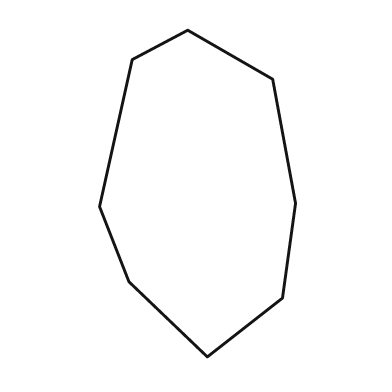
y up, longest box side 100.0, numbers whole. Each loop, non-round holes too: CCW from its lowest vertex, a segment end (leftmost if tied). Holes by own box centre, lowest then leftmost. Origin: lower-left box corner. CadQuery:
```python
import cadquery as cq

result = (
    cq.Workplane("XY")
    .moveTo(33.0, 0.0)
    .lineTo(56.0, 18.0)
    .lineTo(60.0, 47.0)
    .lineTo(53.0, 85.0)
    .lineTo(27.0, 100.0)
    .lineTo(10.0, 91.0)
    .lineTo(0.0, 46.0)
    .lineTo(9.0, 23.0)
    .close()
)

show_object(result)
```